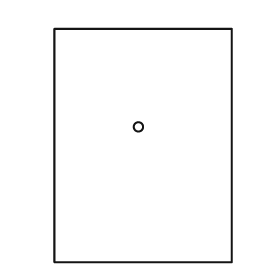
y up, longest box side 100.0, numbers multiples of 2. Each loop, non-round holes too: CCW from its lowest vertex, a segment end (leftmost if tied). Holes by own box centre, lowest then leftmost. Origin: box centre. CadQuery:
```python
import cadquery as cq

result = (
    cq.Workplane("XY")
    .moveTo(-38.0, -50.0)
    .lineTo(38.0, -50.0)
    .lineTo(38.0, 50.0)
    .lineTo(-38.0, 50.0)
    .close()
    .moveTo(-2.0, 8.0)
    .circle(2.0)
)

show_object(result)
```